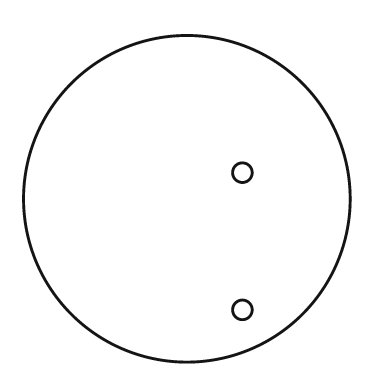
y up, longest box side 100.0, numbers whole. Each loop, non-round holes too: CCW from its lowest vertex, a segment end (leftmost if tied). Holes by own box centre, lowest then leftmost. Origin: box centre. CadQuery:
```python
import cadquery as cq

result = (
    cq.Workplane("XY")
    .moveTo(0.0, 0.0)
    .circle(50.0)
    .moveTo(17.0, -34.0)
    .circle(3.0)
    .moveTo(17.0, 8.0)
    .circle(3.0)
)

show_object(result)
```